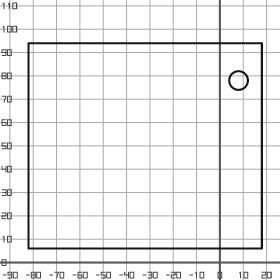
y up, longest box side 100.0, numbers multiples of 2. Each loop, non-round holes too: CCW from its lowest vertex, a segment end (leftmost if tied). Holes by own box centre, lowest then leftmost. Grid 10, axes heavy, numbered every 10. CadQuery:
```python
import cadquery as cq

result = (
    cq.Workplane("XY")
    .moveTo(-82.0, 6.0)
    .lineTo(18.0, 6.0)
    .lineTo(18.0, 94.0)
    .lineTo(-82.0, 94.0)
    .close()
    .moveTo(8.0, 78.0)
    .circle(4.0)
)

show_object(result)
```